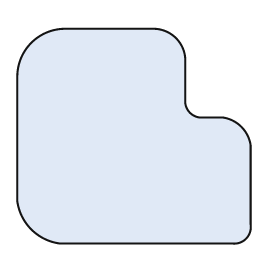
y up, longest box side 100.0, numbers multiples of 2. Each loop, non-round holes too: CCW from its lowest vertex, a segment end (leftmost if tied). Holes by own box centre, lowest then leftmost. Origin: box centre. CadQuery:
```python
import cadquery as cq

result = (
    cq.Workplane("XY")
    .moveTo(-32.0, -46.0)
    .lineTo(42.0, -46.0)
    .threePointArc((48.0, -44.0), (50.0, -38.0))
    .lineTo(50.0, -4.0)
    .threePointArc((46.0, 4.0), (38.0, 8.0))
    .lineTo(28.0, 8.0)
    .threePointArc((24.0, 10.0), (22.0, 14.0))
    .lineTo(22.0, 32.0)
    .threePointArc((18.0, 42.0), (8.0, 46.0))
    .lineTo(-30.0, 46.0)
    .threePointArc((-44.0, 40.0), (-50.0, 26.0))
    .lineTo(-50.0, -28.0)
    .threePointArc((-44.0, -40.0), (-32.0, -46.0))
    .close()
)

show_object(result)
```